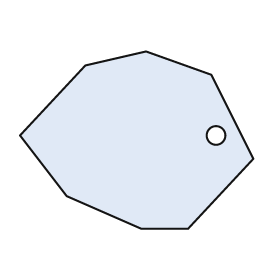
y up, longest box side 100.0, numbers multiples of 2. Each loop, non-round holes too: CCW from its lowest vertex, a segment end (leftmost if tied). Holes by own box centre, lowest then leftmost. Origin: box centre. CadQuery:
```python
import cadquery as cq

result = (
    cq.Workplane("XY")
    .moveTo(2.0, -38.0)
    .lineTo(22.0, -38.0)
    .lineTo(50.0, -8.0)
    .lineTo(32.0, 28.0)
    .lineTo(4.0, 38.0)
    .lineTo(-22.0, 32.0)
    .lineTo(-50.0, 2.0)
    .lineTo(-30.0, -24.0)
    .close()
    .moveTo(34.0, 2.0)
    .circle(4.0)
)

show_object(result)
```